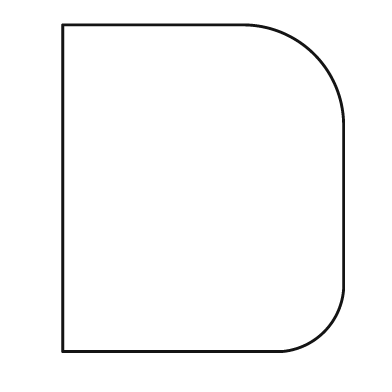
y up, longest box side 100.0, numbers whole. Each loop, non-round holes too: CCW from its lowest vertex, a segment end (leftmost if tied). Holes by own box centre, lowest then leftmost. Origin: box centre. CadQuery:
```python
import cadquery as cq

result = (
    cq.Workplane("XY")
    .moveTo(-43.0, -50.0)
    .lineTo(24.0, -50.0)
    .threePointArc((37.0, -44.0), (43.0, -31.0))
    .lineTo(43.0, 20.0)
    .threePointArc((34.0, 41.0), (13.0, 50.0))
    .lineTo(-43.0, 50.0)
    .close()
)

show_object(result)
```